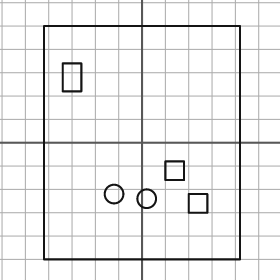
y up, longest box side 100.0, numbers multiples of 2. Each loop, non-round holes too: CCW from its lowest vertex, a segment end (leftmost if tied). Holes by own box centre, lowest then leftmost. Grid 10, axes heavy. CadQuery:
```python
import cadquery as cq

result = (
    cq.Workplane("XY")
    .moveTo(-42.0, -50.0)
    .lineTo(42.0, -50.0)
    .lineTo(42.0, 50.0)
    .lineTo(-42.0, 50.0)
    .close()
    .moveTo(20.0, -30.0)
    .lineTo(28.0, -30.0)
    .lineTo(28.0, -22.0)
    .lineTo(20.0, -22.0)
    .close()
    .moveTo(2.0, -24.0)
    .circle(4.0)
    .moveTo(-12.0, -22.0)
    .circle(4.0)
    .moveTo(10.0, -16.0)
    .lineTo(18.0, -16.0)
    .lineTo(18.0, -8.0)
    .lineTo(10.0, -8.0)
    .close()
    .moveTo(-34.0, 22.0)
    .lineTo(-26.0, 22.0)
    .lineTo(-26.0, 34.0)
    .lineTo(-34.0, 34.0)
    .close()
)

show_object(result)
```